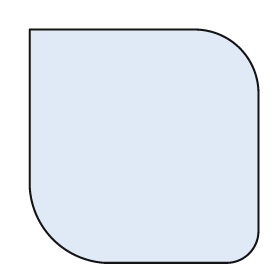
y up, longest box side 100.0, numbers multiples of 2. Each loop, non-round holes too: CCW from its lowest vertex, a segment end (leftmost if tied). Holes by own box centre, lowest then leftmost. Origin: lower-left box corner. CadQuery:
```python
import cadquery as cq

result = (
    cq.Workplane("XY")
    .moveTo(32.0, 0.0)
    .lineTo(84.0, 0.0)
    .threePointArc((94.0, 4.0), (98.0, 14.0))
    .lineTo(98.0, 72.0)
    .threePointArc((90.0, 92.0), (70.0, 100.0))
    .lineTo(0.0, 100.0)
    .lineTo(0.0, 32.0)
    .threePointArc((10.0, 10.0), (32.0, 0.0))
    .close()
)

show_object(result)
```